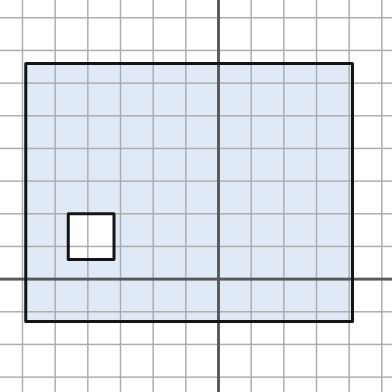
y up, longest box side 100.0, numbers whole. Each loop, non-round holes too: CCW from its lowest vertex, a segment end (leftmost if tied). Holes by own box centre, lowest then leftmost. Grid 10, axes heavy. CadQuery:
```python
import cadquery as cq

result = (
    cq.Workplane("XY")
    .moveTo(-59.0, -13.0)
    .lineTo(41.0, -13.0)
    .lineTo(41.0, 66.0)
    .lineTo(-59.0, 66.0)
    .close()
    .moveTo(-46.0, 6.0)
    .lineTo(-32.0, 6.0)
    .lineTo(-32.0, 20.0)
    .lineTo(-46.0, 20.0)
    .close()
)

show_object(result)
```